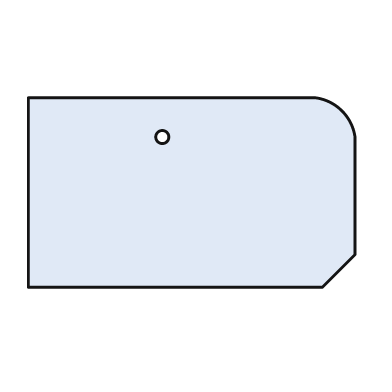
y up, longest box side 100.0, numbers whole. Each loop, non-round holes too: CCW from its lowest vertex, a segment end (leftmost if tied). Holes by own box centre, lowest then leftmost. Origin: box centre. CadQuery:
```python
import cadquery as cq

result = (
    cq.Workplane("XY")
    .moveTo(-50.0, -29.0)
    .lineTo(40.0, -29.0)
    .lineTo(50.0, -19.0)
    .lineTo(50.0, 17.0)
    .threePointArc((46.0, 25.0), (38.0, 29.0))
    .lineTo(-50.0, 29.0)
    .close()
    .moveTo(-9.0, 17.0)
    .circle(2.0)
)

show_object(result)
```